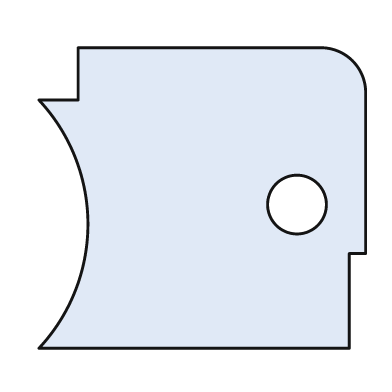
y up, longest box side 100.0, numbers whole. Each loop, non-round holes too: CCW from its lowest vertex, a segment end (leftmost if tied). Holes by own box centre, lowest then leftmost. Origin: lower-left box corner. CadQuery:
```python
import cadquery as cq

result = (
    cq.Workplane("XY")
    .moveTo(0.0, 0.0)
    .lineTo(95.0, 0.0)
    .lineTo(95.0, 29.0)
    .lineTo(100.0, 29.0)
    .lineTo(100.0, 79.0)
    .threePointArc((96.0, 88.0), (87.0, 92.0))
    .lineTo(12.0, 92.0)
    .lineTo(12.0, 76.0)
    .lineTo(0.0, 76.0)
    .threePointArc((15.0, 38.0), (0.0, 0.0))
    .close()
    .moveTo(79.0, 44.0)
    .circle(9.0)
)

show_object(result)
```